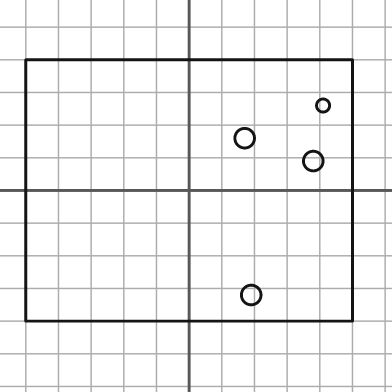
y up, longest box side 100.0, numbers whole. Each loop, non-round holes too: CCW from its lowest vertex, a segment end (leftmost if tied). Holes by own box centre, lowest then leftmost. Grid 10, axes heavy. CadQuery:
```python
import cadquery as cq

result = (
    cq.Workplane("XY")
    .moveTo(-50.0, -40.0)
    .lineTo(50.0, -40.0)
    .lineTo(50.0, 40.0)
    .lineTo(-50.0, 40.0)
    .close()
    .moveTo(19.0, -32.0)
    .circle(3.0)
    .moveTo(38.0, 9.0)
    .circle(3.0)
    .moveTo(17.0, 16.0)
    .circle(3.0)
    .moveTo(41.0, 26.0)
    .circle(2.0)
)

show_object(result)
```